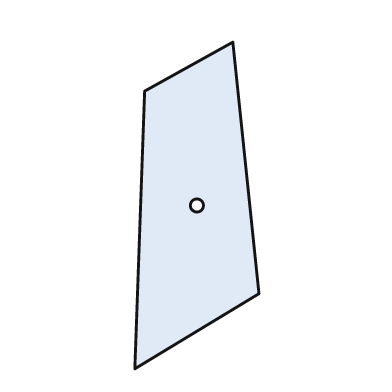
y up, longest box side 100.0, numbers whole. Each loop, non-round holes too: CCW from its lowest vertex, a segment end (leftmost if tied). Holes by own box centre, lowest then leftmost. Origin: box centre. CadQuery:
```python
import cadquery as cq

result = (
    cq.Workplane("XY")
    .moveTo(-19.0, -50.0)
    .lineTo(19.0, -27.0)
    .lineTo(11.0, 50.0)
    .lineTo(-16.0, 35.0)
    .close()
    .moveTo(0.0, 0.0)
    .circle(2.0)
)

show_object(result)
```